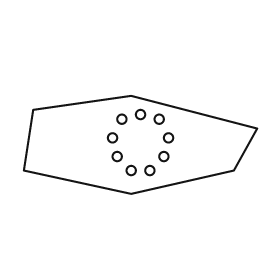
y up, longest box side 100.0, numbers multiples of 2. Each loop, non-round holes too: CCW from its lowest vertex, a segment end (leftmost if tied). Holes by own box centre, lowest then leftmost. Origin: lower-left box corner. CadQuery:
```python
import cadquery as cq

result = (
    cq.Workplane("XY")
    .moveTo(46.0, 0.0)
    .lineTo(90.0, 10.0)
    .lineTo(100.0, 28.0)
    .lineTo(46.0, 42.0)
    .lineTo(4.0, 36.0)
    .lineTo(0.0, 10.0)
    .close()
    .moveTo(46.0, 10.0)
    .circle(2.0)
    .moveTo(54.0, 10.0)
    .circle(2.0)
    .moveTo(40.0, 16.0)
    .circle(2.0)
    .moveTo(60.0, 16.0)
    .circle(2.0)
    .moveTo(38.0, 24.0)
    .circle(2.0)
    .moveTo(62.0, 24.0)
    .circle(2.0)
    .moveTo(42.0, 32.0)
    .circle(2.0)
    .moveTo(58.0, 32.0)
    .circle(2.0)
    .moveTo(50.0, 34.0)
    .circle(2.0)
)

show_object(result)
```